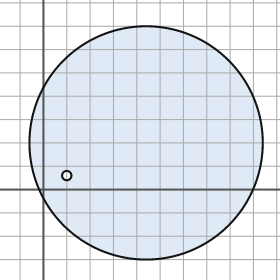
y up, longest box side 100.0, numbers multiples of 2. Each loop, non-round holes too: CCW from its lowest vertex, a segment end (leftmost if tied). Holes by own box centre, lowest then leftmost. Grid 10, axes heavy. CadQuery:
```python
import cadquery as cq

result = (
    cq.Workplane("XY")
    .moveTo(44.0, 20.0)
    .circle(50.0)
    .moveTo(10.0, 6.0)
    .circle(2.0)
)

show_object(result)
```